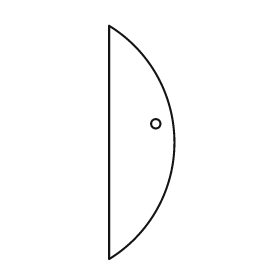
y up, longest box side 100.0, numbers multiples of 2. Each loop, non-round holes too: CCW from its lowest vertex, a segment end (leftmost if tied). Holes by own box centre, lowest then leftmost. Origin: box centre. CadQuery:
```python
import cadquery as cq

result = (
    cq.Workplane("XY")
    .moveTo(-14.0, -50.0)
    .threePointArc((14.0, 0.0), (-14.0, 50.0))
    .close()
    .moveTo(6.0, 8.0)
    .circle(2.0)
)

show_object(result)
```